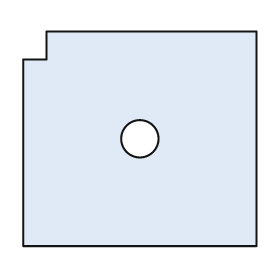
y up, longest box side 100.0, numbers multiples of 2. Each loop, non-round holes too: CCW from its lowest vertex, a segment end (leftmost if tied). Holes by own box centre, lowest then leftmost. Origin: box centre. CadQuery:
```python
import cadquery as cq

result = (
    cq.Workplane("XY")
    .moveTo(-50.0, -46.0)
    .lineTo(50.0, -46.0)
    .lineTo(50.0, 46.0)
    .lineTo(-40.0, 46.0)
    .lineTo(-40.0, 34.0)
    .lineTo(-50.0, 34.0)
    .close()
    .moveTo(0.0, 0.0)
    .circle(8.0)
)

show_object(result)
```